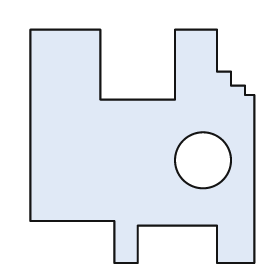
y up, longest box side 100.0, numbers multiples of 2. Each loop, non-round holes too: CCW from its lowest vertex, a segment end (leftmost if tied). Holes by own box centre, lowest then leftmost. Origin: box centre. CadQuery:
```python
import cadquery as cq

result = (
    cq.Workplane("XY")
    .moveTo(-12.0, -50.0)
    .lineTo(-2.0, -50.0)
    .lineTo(-2.0, -34.0)
    .lineTo(32.0, -34.0)
    .lineTo(32.0, -50.0)
    .lineTo(48.0, -50.0)
    .lineTo(48.0, 22.0)
    .lineTo(44.0, 22.0)
    .lineTo(44.0, 26.0)
    .lineTo(38.0, 26.0)
    .lineTo(38.0, 32.0)
    .lineTo(32.0, 32.0)
    .lineTo(32.0, 50.0)
    .lineTo(14.0, 50.0)
    .lineTo(14.0, 20.0)
    .lineTo(-18.0, 20.0)
    .lineTo(-18.0, 50.0)
    .lineTo(-48.0, 50.0)
    .lineTo(-48.0, -32.0)
    .lineTo(-12.0, -32.0)
    .close()
    .moveTo(26.0, -6.0)
    .circle(12.0)
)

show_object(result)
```